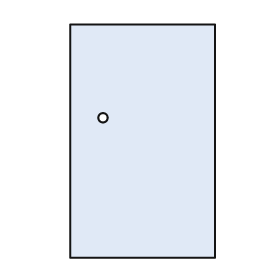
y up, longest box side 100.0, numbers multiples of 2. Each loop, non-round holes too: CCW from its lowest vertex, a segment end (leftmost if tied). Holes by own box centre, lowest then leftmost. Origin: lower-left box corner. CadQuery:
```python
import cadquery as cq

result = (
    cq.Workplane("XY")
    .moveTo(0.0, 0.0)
    .lineTo(62.0, 0.0)
    .lineTo(62.0, 100.0)
    .lineTo(0.0, 100.0)
    .close()
    .moveTo(14.0, 60.0)
    .circle(2.0)
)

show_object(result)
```